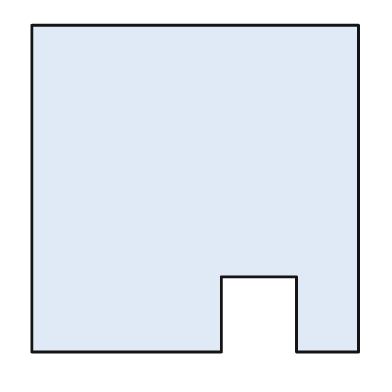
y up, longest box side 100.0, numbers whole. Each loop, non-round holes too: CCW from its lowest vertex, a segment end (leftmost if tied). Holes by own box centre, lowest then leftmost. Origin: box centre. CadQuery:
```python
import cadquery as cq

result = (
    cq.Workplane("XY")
    .moveTo(-50.0, -50.0)
    .lineTo(8.0, -50.0)
    .lineTo(8.0, -27.0)
    .lineTo(31.0, -27.0)
    .lineTo(31.0, -50.0)
    .lineTo(50.0, -50.0)
    .lineTo(50.0, 50.0)
    .lineTo(-50.0, 50.0)
    .close()
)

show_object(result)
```